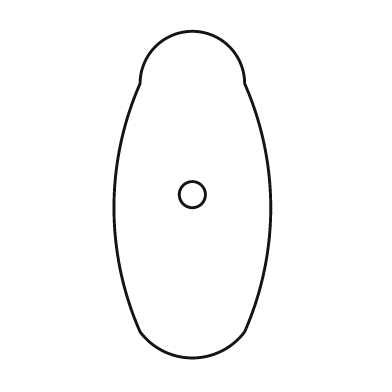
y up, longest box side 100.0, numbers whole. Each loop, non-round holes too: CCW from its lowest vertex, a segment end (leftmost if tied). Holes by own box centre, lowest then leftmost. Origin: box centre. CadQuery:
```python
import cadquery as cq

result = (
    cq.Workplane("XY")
    .moveTo(-16.0, -42.0)
    .threePointArc((0.0, -50.0), (16.0, -42.0))
    .threePointArc((24.0, -4.0), (16.0, 34.0))
    .threePointArc((0.0, 50.0), (-16.0, 34.0))
    .threePointArc((-24.0, -4.0), (-16.0, -42.0))
    .close()
    .moveTo(0.0, 0.0)
    .circle(4.0)
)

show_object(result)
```